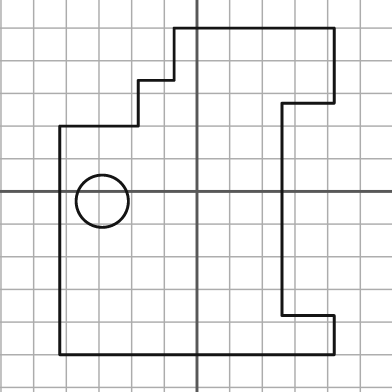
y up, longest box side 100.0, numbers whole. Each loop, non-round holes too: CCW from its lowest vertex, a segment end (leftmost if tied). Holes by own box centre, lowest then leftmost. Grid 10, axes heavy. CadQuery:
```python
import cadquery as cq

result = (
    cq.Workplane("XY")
    .moveTo(-42.0, -50.0)
    .lineTo(42.0, -50.0)
    .lineTo(42.0, -38.0)
    .lineTo(26.0, -38.0)
    .lineTo(26.0, 27.0)
    .lineTo(42.0, 27.0)
    .lineTo(42.0, 50.0)
    .lineTo(-7.0, 50.0)
    .lineTo(-7.0, 34.0)
    .lineTo(-18.0, 34.0)
    .lineTo(-18.0, 20.0)
    .lineTo(-42.0, 20.0)
    .close()
    .moveTo(-29.0, -3.0)
    .circle(8.0)
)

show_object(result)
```